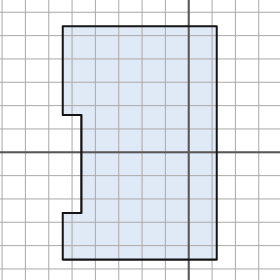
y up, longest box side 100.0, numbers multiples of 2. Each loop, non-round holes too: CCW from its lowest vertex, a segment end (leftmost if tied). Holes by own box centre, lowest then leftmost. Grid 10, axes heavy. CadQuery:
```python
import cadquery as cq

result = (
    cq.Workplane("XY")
    .moveTo(-54.0, -46.0)
    .lineTo(12.0, -46.0)
    .lineTo(12.0, 54.0)
    .lineTo(-54.0, 54.0)
    .lineTo(-54.0, 16.0)
    .lineTo(-46.0, 16.0)
    .lineTo(-46.0, -26.0)
    .lineTo(-54.0, -26.0)
    .close()
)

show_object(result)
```